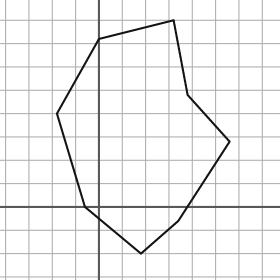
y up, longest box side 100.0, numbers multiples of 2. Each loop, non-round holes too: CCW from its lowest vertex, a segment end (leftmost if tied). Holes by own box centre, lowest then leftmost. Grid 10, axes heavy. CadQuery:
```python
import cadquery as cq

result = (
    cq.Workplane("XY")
    .moveTo(18.0, -20.0)
    .lineTo(34.0, -6.0)
    .lineTo(56.0, 28.0)
    .lineTo(38.0, 48.0)
    .lineTo(32.0, 80.0)
    .lineTo(0.0, 72.0)
    .lineTo(-18.0, 40.0)
    .lineTo(-6.0, 0.0)
    .close()
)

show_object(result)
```